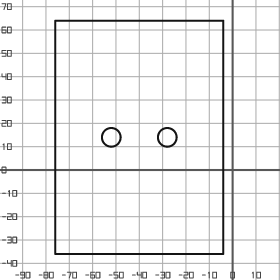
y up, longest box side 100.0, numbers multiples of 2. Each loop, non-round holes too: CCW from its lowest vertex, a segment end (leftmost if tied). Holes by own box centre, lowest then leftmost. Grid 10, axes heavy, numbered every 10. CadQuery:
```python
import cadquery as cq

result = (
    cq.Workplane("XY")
    .moveTo(-76.0, -36.0)
    .lineTo(-4.0, -36.0)
    .lineTo(-4.0, 64.0)
    .lineTo(-76.0, 64.0)
    .close()
    .moveTo(-52.0, 14.0)
    .circle(4.0)
    .moveTo(-28.0, 14.0)
    .circle(4.0)
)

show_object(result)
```